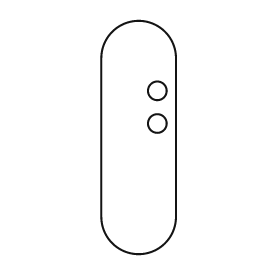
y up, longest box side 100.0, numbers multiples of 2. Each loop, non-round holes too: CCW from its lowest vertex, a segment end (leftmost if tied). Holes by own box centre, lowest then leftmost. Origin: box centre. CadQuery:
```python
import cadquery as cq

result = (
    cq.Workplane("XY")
    .moveTo(-16.0, -34.0)
    .threePointArc((0.0, -50.0), (16.0, -34.0))
    .lineTo(16.0, 34.0)
    .threePointArc((0.0, 50.0), (-16.0, 34.0))
    .close()
    .moveTo(8.0, 6.0)
    .circle(4.0)
    .moveTo(8.0, 20.0)
    .circle(4.0)
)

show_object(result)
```